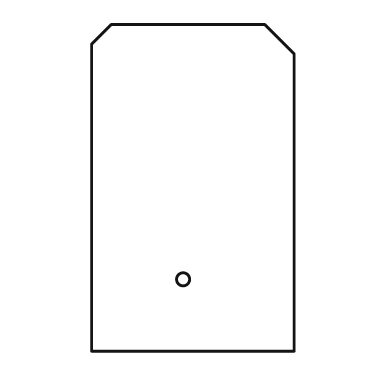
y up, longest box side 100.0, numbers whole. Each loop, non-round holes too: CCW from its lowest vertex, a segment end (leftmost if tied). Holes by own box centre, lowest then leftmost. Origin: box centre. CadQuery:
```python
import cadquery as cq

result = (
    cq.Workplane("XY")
    .moveTo(-31.0, -50.0)
    .lineTo(31.0, -50.0)
    .lineTo(31.0, 41.0)
    .lineTo(22.0, 50.0)
    .lineTo(-25.0, 50.0)
    .lineTo(-31.0, 44.0)
    .close()
    .moveTo(-3.0, -28.0)
    .circle(2.0)
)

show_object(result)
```